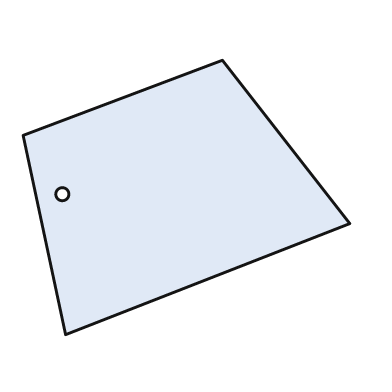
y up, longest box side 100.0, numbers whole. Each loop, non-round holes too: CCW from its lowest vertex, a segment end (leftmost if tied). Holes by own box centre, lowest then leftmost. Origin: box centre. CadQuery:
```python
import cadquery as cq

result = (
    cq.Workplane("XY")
    .moveTo(-37.0, -42.0)
    .lineTo(50.0, -8.0)
    .lineTo(11.0, 42.0)
    .lineTo(-50.0, 19.0)
    .close()
    .moveTo(-38.0, 1.0)
    .circle(2.0)
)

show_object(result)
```